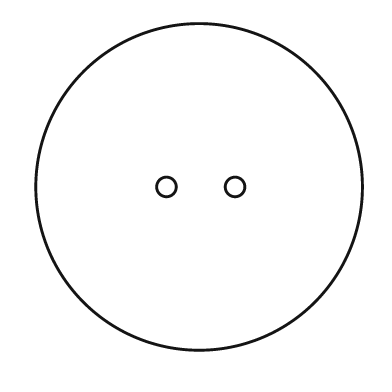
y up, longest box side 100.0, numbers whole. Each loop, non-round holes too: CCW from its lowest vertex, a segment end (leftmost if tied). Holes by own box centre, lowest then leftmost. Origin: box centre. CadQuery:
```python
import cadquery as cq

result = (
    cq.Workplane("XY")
    .moveTo(0.0, 0.0)
    .circle(50.0)
    .moveTo(-10.0, 0.0)
    .circle(3.0)
    .moveTo(11.0, 0.0)
    .circle(3.0)
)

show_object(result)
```